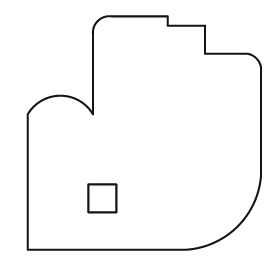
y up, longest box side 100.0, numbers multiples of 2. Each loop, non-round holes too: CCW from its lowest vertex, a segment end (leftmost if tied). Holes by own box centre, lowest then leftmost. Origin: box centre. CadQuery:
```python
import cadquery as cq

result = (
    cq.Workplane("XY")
    .moveTo(-50.0, -50.0)
    .lineTo(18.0, -50.0)
    .threePointArc((40.0, -40.0), (50.0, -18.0))
    .lineTo(50.0, 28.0)
    .threePointArc((48.0, 32.0), (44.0, 34.0))
    .lineTo(26.0, 34.0)
    .lineTo(26.0, 46.0)
    .lineTo(10.0, 46.0)
    .lineTo(10.0, 50.0)
    .lineTo(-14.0, 50.0)
    .threePointArc((-20.0, 48.0), (-22.0, 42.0))
    .lineTo(-22.0, 8.0)
    .threePointArc((-36.0, 16.0), (-50.0, 8.0))
    .close()
    .moveTo(-24.0, -34.0)
    .lineTo(-12.0, -34.0)
    .lineTo(-12.0, -22.0)
    .lineTo(-24.0, -22.0)
    .close()
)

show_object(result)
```